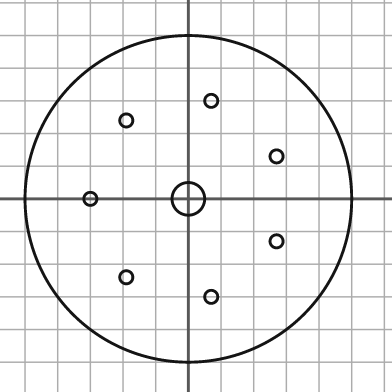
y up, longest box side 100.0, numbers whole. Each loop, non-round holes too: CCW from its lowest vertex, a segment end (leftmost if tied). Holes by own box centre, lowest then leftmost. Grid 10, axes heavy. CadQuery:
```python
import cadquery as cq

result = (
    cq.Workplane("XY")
    .moveTo(0.0, 0.0)
    .circle(50.0)
    .moveTo(7.0, -30.0)
    .circle(2.0)
    .moveTo(-19.0, -24.0)
    .circle(2.0)
    .moveTo(27.0, -13.0)
    .circle(2.0)
    .moveTo(-30.0, 0.0)
    .circle(2.0)
    .moveTo(0.0, 0.0)
    .circle(5.0)
    .moveTo(27.0, 13.0)
    .circle(2.0)
    .moveTo(-19.0, 24.0)
    .circle(2.0)
    .moveTo(7.0, 30.0)
    .circle(2.0)
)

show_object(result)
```